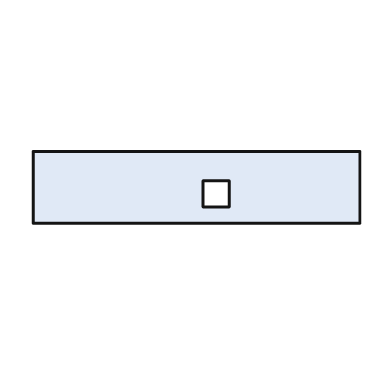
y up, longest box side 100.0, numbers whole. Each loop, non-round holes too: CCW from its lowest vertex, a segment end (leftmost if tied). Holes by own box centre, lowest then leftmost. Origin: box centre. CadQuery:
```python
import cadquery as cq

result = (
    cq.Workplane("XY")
    .moveTo(-50.0, -11.0)
    .lineTo(50.0, -11.0)
    .lineTo(50.0, 11.0)
    .lineTo(-50.0, 11.0)
    .close()
    .moveTo(2.0, -6.0)
    .lineTo(10.0, -6.0)
    .lineTo(10.0, 2.0)
    .lineTo(2.0, 2.0)
    .close()
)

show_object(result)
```